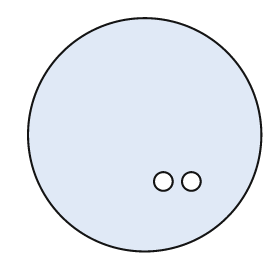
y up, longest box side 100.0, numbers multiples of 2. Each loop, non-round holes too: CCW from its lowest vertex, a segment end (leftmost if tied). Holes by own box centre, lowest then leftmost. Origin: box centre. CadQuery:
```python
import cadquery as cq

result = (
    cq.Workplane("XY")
    .moveTo(0.0, 0.0)
    .circle(50.0)
    .moveTo(8.0, -20.0)
    .circle(4.0)
    .moveTo(20.0, -20.0)
    .circle(4.0)
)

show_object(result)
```